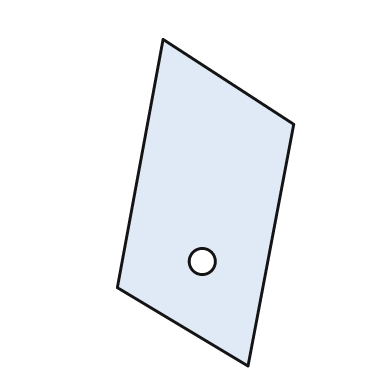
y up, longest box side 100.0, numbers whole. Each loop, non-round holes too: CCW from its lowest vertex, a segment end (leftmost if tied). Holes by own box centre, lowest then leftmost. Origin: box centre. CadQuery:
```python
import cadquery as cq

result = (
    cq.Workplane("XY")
    .moveTo(13.0, -50.0)
    .lineTo(27.0, 24.0)
    .lineTo(-13.0, 50.0)
    .lineTo(-27.0, -26.0)
    .close()
    .moveTo(-1.0, -18.0)
    .circle(4.0)
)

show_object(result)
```